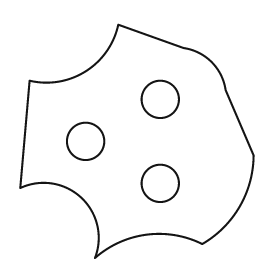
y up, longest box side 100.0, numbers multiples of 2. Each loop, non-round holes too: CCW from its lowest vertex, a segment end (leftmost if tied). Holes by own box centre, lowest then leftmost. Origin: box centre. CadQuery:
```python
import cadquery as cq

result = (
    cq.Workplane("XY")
    .moveTo(-18.0, -50.0)
    .threePointArc((4.0, -40.0), (28.0, -44.0))
    .threePointArc((44.0, -28.0), (50.0, -6.0))
    .lineTo(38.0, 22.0)
    .threePointArc((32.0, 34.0), (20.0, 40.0))
    .lineTo(-8.0, 50.0)
    .threePointArc((-22.0, 30.0), (-46.0, 26.0))
    .lineTo(-50.0, -20.0)
    .threePointArc((-24.0, -24.0), (-18.0, -50.0))
    .close()
    .moveTo(10.0, -18.0)
    .circle(8.0)
    .moveTo(-22.0, 0.0)
    .circle(8.0)
    .moveTo(10.0, 18.0)
    .circle(8.0)
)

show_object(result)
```